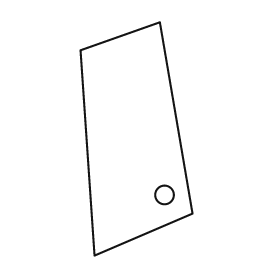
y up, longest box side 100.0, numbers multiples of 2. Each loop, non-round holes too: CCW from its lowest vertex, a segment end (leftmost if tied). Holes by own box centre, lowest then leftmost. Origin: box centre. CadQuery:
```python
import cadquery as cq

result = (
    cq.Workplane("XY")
    .moveTo(-18.0, -50.0)
    .lineTo(24.0, -32.0)
    .lineTo(10.0, 50.0)
    .lineTo(-24.0, 38.0)
    .close()
    .moveTo(12.0, -24.0)
    .circle(4.0)
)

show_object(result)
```